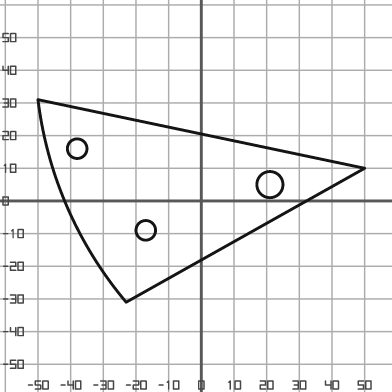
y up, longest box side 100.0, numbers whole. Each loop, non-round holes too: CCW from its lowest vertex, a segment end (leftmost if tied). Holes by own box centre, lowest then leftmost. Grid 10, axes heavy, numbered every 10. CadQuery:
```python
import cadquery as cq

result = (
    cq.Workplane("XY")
    .moveTo(-23.0, -31.0)
    .lineTo(50.0, 10.0)
    .lineTo(-50.0, 31.0)
    .threePointArc((-41.0, -2.0), (-23.0, -31.0))
    .close()
    .moveTo(-17.0, -9.0)
    .circle(3.0)
    .moveTo(21.0, 5.0)
    .circle(4.0)
    .moveTo(-38.0, 16.0)
    .circle(3.0)
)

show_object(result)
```